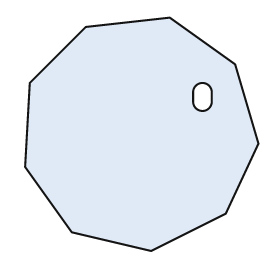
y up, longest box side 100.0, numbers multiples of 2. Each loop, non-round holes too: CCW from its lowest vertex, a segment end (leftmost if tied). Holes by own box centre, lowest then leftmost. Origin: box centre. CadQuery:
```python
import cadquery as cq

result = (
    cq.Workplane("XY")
    .moveTo(4.0, -50.0)
    .lineTo(36.0, -34.0)
    .lineTo(50.0, -4.0)
    .lineTo(40.0, 30.0)
    .lineTo(12.0, 50.0)
    .lineTo(-24.0, 46.0)
    .lineTo(-48.0, 22.0)
    .lineTo(-50.0, -14.0)
    .lineTo(-30.0, -42.0)
    .close()
    .moveTo(22.0, 14.0)
    .threePointArc((26.0, 10.0), (30.0, 14.0))
    .lineTo(30.0, 18.0)
    .threePointArc((26.0, 22.0), (22.0, 18.0))
    .close()
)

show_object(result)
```